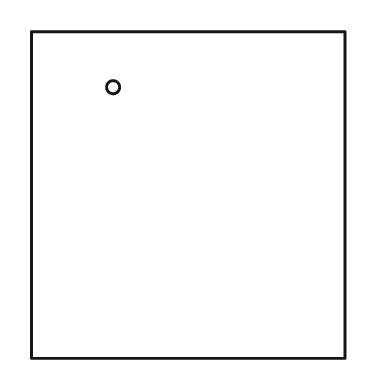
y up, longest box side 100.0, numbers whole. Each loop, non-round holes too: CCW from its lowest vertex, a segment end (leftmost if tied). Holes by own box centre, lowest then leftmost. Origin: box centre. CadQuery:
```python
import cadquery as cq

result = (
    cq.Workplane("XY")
    .moveTo(-48.0, -50.0)
    .lineTo(48.0, -50.0)
    .lineTo(48.0, 50.0)
    .lineTo(-48.0, 50.0)
    .close()
    .moveTo(-23.0, 33.0)
    .circle(2.0)
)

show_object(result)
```